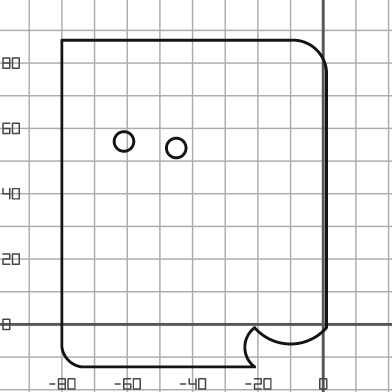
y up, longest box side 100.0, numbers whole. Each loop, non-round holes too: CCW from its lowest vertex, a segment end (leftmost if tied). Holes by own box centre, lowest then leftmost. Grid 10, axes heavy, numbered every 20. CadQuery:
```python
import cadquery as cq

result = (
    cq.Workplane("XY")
    .moveTo(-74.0, -13.0)
    .lineTo(-21.0, -13.0)
    .threePointArc((-24.0, -7.0), (-21.0, -1.0))
    .threePointArc((-10.0, -6.0), (1.0, -1.0))
    .lineTo(1.0, 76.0)
    .threePointArc((-2.0, 84.0), (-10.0, 87.0))
    .lineTo(-80.0, 87.0)
    .lineTo(-80.0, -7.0)
    .threePointArc((-78.0, -11.0), (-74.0, -13.0))
    .close()
    .moveTo(-45.0, 54.0)
    .circle(3.0)
    .moveTo(-61.0, 56.0)
    .circle(3.0)
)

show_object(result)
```